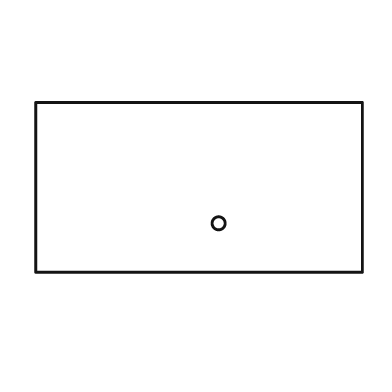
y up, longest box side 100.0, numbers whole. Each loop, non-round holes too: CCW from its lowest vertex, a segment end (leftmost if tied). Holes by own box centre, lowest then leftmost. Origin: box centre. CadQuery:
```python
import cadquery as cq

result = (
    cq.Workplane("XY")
    .moveTo(-50.0, -26.0)
    .lineTo(50.0, -26.0)
    .lineTo(50.0, 26.0)
    .lineTo(-50.0, 26.0)
    .close()
    .moveTo(6.0, -11.0)
    .circle(2.0)
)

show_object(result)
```